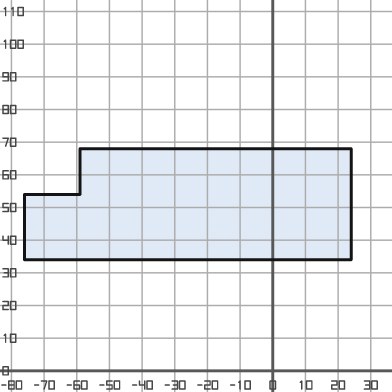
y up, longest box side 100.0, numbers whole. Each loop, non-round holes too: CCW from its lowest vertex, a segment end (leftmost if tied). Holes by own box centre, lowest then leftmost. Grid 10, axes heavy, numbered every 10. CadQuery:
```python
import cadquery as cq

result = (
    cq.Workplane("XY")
    .moveTo(-76.0, 34.0)
    .lineTo(24.0, 34.0)
    .lineTo(24.0, 68.0)
    .lineTo(-59.0, 68.0)
    .lineTo(-59.0, 54.0)
    .lineTo(-76.0, 54.0)
    .close()
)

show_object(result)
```